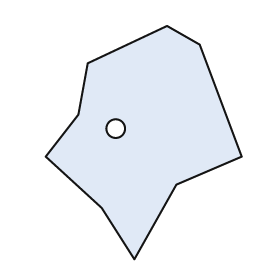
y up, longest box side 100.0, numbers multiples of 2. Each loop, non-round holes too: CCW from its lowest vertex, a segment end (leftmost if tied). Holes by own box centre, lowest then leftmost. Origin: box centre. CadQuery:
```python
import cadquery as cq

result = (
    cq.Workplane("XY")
    .moveTo(-4.0, -50.0)
    .lineTo(14.0, -18.0)
    .lineTo(42.0, -6.0)
    .lineTo(24.0, 42.0)
    .lineTo(10.0, 50.0)
    .lineTo(-24.0, 34.0)
    .lineTo(-28.0, 12.0)
    .lineTo(-42.0, -6.0)
    .lineTo(-18.0, -28.0)
    .close()
    .moveTo(-12.0, 6.0)
    .circle(4.0)
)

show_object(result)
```